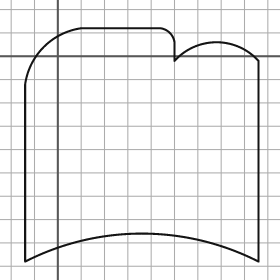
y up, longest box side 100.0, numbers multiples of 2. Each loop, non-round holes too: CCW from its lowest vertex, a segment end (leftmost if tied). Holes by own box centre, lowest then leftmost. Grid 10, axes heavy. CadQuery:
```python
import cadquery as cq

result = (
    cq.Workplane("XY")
    .moveTo(-14.0, -88.0)
    .threePointArc((36.0, -76.0), (86.0, -88.0))
    .lineTo(86.0, -2.0)
    .threePointArc((68.0, 6.0), (50.0, -2.0))
    .lineTo(50.0, 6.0)
    .threePointArc((48.0, 10.0), (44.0, 12.0))
    .lineTo(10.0, 12.0)
    .threePointArc((-6.0, 4.0), (-14.0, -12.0))
    .close()
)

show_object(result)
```